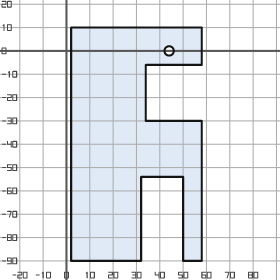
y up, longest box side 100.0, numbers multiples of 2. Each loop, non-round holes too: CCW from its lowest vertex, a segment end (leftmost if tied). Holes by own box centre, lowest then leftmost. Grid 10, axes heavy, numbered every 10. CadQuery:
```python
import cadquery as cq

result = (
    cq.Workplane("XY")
    .moveTo(2.0, -90.0)
    .lineTo(32.0, -90.0)
    .lineTo(32.0, -54.0)
    .lineTo(50.0, -54.0)
    .lineTo(50.0, -90.0)
    .lineTo(58.0, -90.0)
    .lineTo(58.0, -30.0)
    .lineTo(34.0, -30.0)
    .lineTo(34.0, -6.0)
    .lineTo(58.0, -6.0)
    .lineTo(58.0, 10.0)
    .lineTo(2.0, 10.0)
    .close()
    .moveTo(44.0, 0.0)
    .circle(2.0)
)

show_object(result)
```